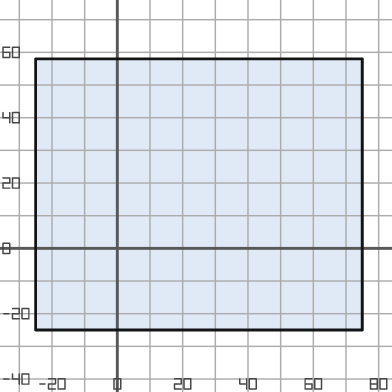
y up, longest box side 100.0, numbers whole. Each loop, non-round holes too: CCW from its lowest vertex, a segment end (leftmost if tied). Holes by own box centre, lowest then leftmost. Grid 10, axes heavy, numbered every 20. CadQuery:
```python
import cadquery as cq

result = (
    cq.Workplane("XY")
    .moveTo(-25.0, -25.0)
    .lineTo(75.0, -25.0)
    .lineTo(75.0, 58.0)
    .lineTo(-25.0, 58.0)
    .close()
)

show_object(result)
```